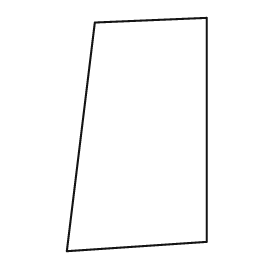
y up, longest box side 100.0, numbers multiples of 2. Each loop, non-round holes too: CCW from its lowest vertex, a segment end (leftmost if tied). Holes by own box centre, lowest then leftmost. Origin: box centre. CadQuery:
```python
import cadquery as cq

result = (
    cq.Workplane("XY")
    .moveTo(-30.0, -50.0)
    .lineTo(30.0, -46.0)
    .lineTo(30.0, 50.0)
    .lineTo(-18.0, 48.0)
    .close()
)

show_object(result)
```